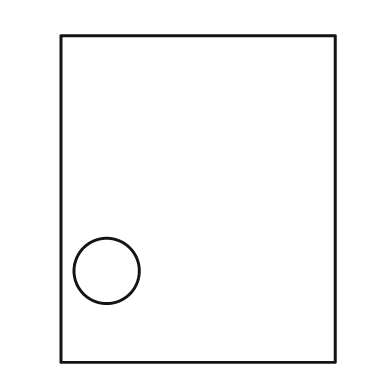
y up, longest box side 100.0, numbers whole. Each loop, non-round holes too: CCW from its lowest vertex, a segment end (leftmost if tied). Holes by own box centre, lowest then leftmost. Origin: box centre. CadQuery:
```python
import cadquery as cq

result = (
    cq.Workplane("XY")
    .moveTo(-42.0, -50.0)
    .lineTo(42.0, -50.0)
    .lineTo(42.0, 50.0)
    .lineTo(-42.0, 50.0)
    .close()
    .moveTo(-28.0, -22.0)
    .circle(10.0)
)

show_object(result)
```